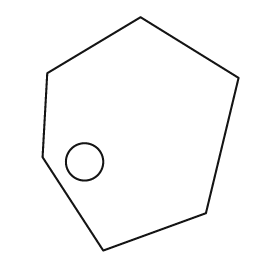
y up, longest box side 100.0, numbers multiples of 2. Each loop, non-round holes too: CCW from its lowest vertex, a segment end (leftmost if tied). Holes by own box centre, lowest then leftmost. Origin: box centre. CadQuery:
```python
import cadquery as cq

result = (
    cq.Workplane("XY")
    .moveTo(-16.0, -50.0)
    .lineTo(28.0, -34.0)
    .lineTo(42.0, 24.0)
    .lineTo(0.0, 50.0)
    .lineTo(-40.0, 26.0)
    .lineTo(-42.0, -10.0)
    .close()
    .moveTo(-24.0, -12.0)
    .circle(8.0)
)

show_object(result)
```